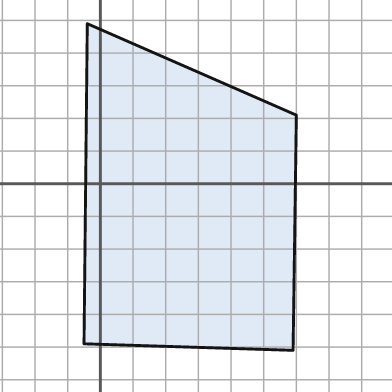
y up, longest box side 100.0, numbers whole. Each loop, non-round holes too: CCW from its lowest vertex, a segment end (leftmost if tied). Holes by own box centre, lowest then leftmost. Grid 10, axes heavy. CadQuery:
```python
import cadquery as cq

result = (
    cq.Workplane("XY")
    .moveTo(59.0, -51.0)
    .lineTo(60.0, 21.0)
    .lineTo(-4.0, 49.0)
    .lineTo(-5.0, -49.0)
    .close()
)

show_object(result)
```